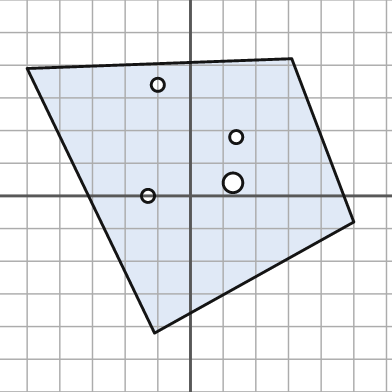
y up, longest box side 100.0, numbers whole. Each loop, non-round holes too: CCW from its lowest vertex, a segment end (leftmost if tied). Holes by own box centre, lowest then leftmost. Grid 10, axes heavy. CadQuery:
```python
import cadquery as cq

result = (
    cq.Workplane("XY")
    .moveTo(-11.0, -42.0)
    .lineTo(50.0, -8.0)
    .lineTo(31.0, 42.0)
    .lineTo(-50.0, 39.0)
    .close()
    .moveTo(-13.0, 0.0)
    .circle(2.0)
    .moveTo(13.0, 4.0)
    .circle(3.0)
    .moveTo(14.0, 18.0)
    .circle(2.0)
    .moveTo(-10.0, 34.0)
    .circle(2.0)
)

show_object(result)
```